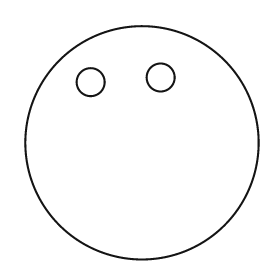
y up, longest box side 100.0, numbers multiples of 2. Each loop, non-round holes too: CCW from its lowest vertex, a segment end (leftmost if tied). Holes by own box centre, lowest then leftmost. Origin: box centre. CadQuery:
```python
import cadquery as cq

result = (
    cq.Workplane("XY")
    .moveTo(0.0, 0.0)
    .circle(50.0)
    .moveTo(-22.0, 26.0)
    .circle(6.0)
    .moveTo(8.0, 28.0)
    .circle(6.0)
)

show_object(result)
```